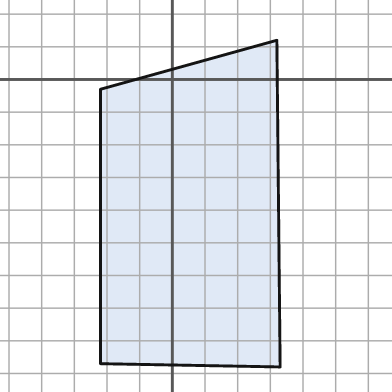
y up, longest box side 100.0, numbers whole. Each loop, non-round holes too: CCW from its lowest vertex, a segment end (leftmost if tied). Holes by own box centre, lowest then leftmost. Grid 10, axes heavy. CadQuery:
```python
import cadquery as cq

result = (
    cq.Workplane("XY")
    .moveTo(33.0, -88.0)
    .lineTo(32.0, 12.0)
    .lineTo(-22.0, -3.0)
    .lineTo(-22.0, -87.0)
    .close()
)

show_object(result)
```